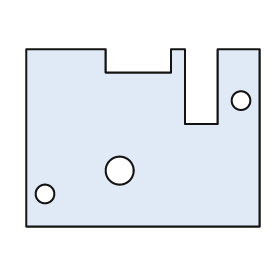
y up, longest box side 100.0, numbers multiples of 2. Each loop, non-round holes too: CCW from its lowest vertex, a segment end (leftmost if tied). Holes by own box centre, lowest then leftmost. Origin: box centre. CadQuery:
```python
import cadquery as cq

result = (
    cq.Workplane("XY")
    .moveTo(-50.0, -38.0)
    .lineTo(50.0, -38.0)
    .lineTo(50.0, 38.0)
    .lineTo(32.0, 38.0)
    .lineTo(32.0, 6.0)
    .lineTo(18.0, 6.0)
    .lineTo(18.0, 38.0)
    .lineTo(12.0, 38.0)
    .lineTo(12.0, 28.0)
    .lineTo(-16.0, 28.0)
    .lineTo(-16.0, 38.0)
    .lineTo(-50.0, 38.0)
    .close()
    .moveTo(-42.0, -24.0)
    .circle(4.0)
    .moveTo(-10.0, -14.0)
    .circle(6.0)
    .moveTo(42.0, 16.0)
    .circle(4.0)
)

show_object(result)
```